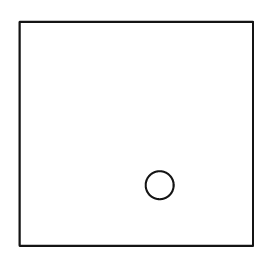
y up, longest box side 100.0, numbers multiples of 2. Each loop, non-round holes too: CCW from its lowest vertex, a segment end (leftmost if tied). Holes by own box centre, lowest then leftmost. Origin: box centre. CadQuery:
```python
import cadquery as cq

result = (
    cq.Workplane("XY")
    .moveTo(-50.0, -48.0)
    .lineTo(50.0, -48.0)
    .lineTo(50.0, 48.0)
    .lineTo(-50.0, 48.0)
    .close()
    .moveTo(10.0, -22.0)
    .circle(6.0)
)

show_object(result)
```